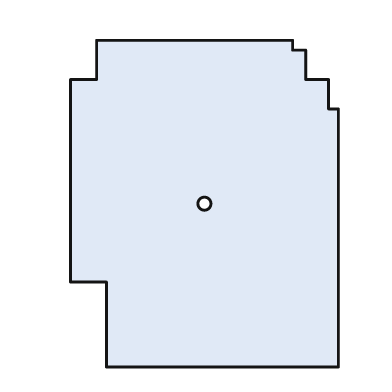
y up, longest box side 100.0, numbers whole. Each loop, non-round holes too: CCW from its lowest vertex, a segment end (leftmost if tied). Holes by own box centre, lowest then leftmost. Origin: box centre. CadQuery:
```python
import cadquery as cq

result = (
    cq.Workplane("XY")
    .moveTo(-30.0, -50.0)
    .lineTo(41.0, -50.0)
    .lineTo(41.0, 29.0)
    .lineTo(38.0, 29.0)
    .lineTo(38.0, 38.0)
    .lineTo(31.0, 38.0)
    .lineTo(31.0, 47.0)
    .lineTo(27.0, 47.0)
    .lineTo(27.0, 50.0)
    .lineTo(-33.0, 50.0)
    .lineTo(-33.0, 38.0)
    .lineTo(-41.0, 38.0)
    .lineTo(-41.0, -24.0)
    .lineTo(-30.0, -24.0)
    .close()
    .moveTo(0.0, 0.0)
    .circle(2.0)
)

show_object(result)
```